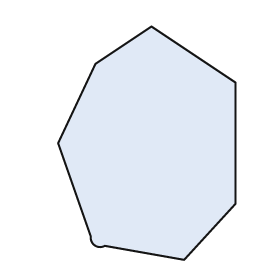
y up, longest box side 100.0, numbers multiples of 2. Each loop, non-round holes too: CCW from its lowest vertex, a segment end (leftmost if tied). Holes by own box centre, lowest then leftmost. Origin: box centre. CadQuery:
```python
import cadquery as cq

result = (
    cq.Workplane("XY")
    .moveTo(16.0, -50.0)
    .lineTo(38.0, -26.0)
    .lineTo(38.0, 26.0)
    .lineTo(2.0, 50.0)
    .lineTo(-22.0, 34.0)
    .lineTo(-38.0, 0.0)
    .lineTo(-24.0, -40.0)
    .threePointArc((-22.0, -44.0), (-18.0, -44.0))
    .close()
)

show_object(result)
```